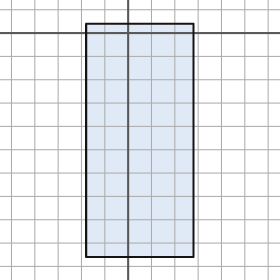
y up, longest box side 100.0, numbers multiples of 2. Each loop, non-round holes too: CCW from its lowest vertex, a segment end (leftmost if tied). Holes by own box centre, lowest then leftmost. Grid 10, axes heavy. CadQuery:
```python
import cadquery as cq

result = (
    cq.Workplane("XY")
    .moveTo(-18.0, -96.0)
    .lineTo(28.0, -96.0)
    .lineTo(28.0, 4.0)
    .lineTo(-18.0, 4.0)
    .close()
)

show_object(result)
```